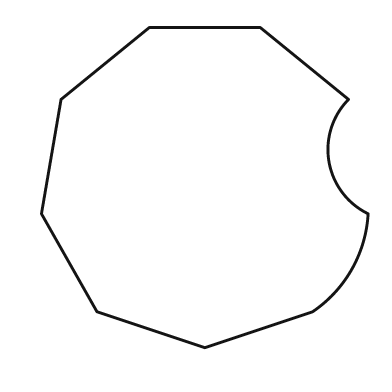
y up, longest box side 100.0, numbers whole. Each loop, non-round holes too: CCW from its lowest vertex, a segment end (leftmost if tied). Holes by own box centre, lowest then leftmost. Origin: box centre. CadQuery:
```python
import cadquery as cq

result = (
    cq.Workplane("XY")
    .moveTo(0.0, -49.0)
    .lineTo(33.0, -38.0)
    .threePointArc((45.0, -25.0), (50.0, -8.0))
    .threePointArc((38.0, 8.0), (44.0, 27.0))
    .lineTo(17.0, 49.0)
    .lineTo(-17.0, 49.0)
    .lineTo(-44.0, 27.0)
    .lineTo(-50.0, -8.0)
    .lineTo(-33.0, -38.0)
    .close()
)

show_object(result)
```